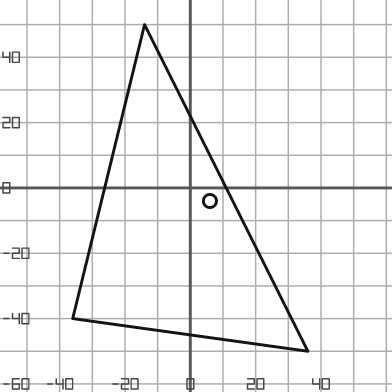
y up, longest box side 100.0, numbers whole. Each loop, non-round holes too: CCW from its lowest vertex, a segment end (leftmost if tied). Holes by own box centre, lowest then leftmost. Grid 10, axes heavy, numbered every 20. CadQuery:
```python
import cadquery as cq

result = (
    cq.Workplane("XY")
    .moveTo(36.0, -50.0)
    .lineTo(-14.0, 50.0)
    .lineTo(-36.0, -40.0)
    .close()
    .moveTo(6.0, -4.0)
    .circle(2.0)
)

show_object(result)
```